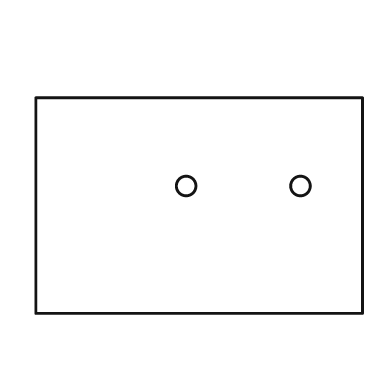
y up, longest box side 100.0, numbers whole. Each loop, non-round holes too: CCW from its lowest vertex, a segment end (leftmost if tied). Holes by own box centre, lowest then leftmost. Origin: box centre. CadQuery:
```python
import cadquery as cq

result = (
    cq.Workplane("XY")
    .moveTo(-50.0, -33.0)
    .lineTo(50.0, -33.0)
    .lineTo(50.0, 33.0)
    .lineTo(-50.0, 33.0)
    .close()
    .moveTo(-4.0, 6.0)
    .circle(3.0)
    .moveTo(31.0, 6.0)
    .circle(3.0)
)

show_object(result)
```